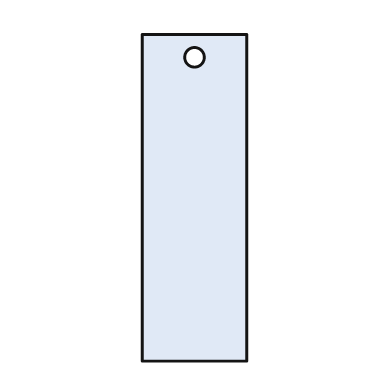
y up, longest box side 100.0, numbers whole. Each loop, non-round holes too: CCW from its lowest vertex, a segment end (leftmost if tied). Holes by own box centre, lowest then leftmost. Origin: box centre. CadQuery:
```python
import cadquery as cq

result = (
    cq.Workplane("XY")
    .moveTo(-16.0, -50.0)
    .lineTo(16.0, -50.0)
    .lineTo(16.0, 50.0)
    .lineTo(-16.0, 50.0)
    .close()
    .moveTo(0.0, 43.0)
    .circle(3.0)
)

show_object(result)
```